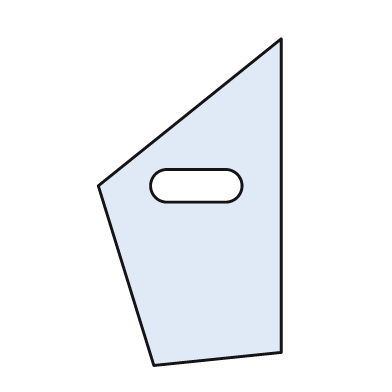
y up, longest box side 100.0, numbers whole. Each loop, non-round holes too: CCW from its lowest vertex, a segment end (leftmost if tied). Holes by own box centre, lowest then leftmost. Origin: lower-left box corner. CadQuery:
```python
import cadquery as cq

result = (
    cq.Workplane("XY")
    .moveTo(17.0, 0.0)
    .lineTo(56.0, 4.0)
    .lineTo(56.0, 100.0)
    .lineTo(0.0, 55.0)
    .close()
    .moveTo(21.0, 50.0)
    .lineTo(39.0, 50.0)
    .threePointArc((44.0, 55.0), (39.0, 60.0))
    .lineTo(21.0, 60.0)
    .threePointArc((16.0, 55.0), (21.0, 50.0))
    .close()
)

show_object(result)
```